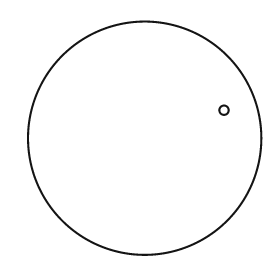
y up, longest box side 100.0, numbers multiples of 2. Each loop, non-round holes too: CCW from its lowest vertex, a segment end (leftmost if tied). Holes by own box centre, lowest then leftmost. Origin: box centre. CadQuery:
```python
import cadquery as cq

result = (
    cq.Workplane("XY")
    .moveTo(0.0, 0.0)
    .circle(50.0)
    .moveTo(34.0, 12.0)
    .circle(2.0)
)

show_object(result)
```